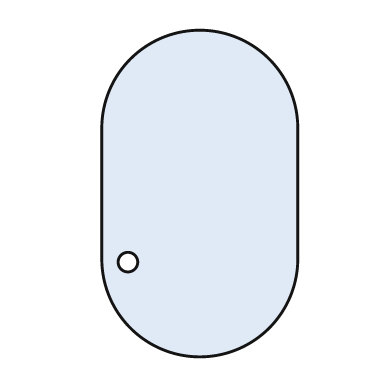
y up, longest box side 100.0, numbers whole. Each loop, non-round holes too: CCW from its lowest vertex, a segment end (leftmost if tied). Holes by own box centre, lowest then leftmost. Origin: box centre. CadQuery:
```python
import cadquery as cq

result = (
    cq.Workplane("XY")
    .moveTo(-30.0, -20.0)
    .threePointArc((0.0, -50.0), (30.0, -20.0))
    .lineTo(30.0, 20.0)
    .threePointArc((0.0, 50.0), (-30.0, 20.0))
    .close()
    .moveTo(-22.0, -21.0)
    .circle(3.0)
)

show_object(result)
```